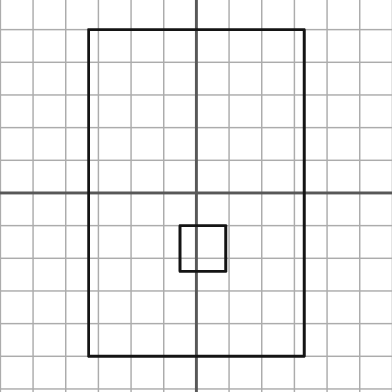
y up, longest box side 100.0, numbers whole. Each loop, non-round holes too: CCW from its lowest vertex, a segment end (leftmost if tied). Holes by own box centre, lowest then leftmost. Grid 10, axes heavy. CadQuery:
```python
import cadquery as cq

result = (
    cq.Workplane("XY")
    .moveTo(-33.0, -50.0)
    .lineTo(33.0, -50.0)
    .lineTo(33.0, 50.0)
    .lineTo(-33.0, 50.0)
    .close()
    .moveTo(-5.0, -24.0)
    .lineTo(9.0, -24.0)
    .lineTo(9.0, -10.0)
    .lineTo(-5.0, -10.0)
    .close()
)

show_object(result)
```